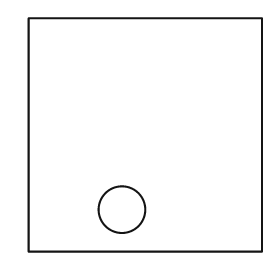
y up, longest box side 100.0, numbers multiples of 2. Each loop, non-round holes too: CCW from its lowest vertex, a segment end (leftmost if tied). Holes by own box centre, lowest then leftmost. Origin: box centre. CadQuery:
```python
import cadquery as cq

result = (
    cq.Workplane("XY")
    .moveTo(-50.0, -50.0)
    .lineTo(50.0, -50.0)
    .lineTo(50.0, 50.0)
    .lineTo(-50.0, 50.0)
    .close()
    .moveTo(-10.0, -32.0)
    .circle(10.0)
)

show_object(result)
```